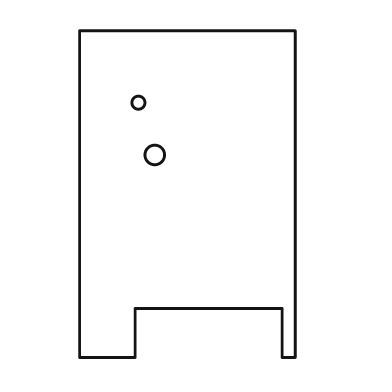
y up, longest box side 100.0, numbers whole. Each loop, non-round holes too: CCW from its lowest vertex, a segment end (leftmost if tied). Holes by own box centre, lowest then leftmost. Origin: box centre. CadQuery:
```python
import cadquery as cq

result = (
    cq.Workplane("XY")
    .moveTo(-33.0, -50.0)
    .lineTo(-16.0, -50.0)
    .lineTo(-16.0, -35.0)
    .lineTo(29.0, -35.0)
    .lineTo(29.0, -50.0)
    .lineTo(33.0, -50.0)
    .lineTo(33.0, 50.0)
    .lineTo(-33.0, 50.0)
    .close()
    .moveTo(-10.0, 12.0)
    .circle(3.0)
    .moveTo(-15.0, 28.0)
    .circle(2.0)
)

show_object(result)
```